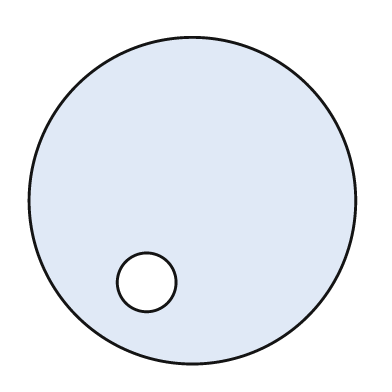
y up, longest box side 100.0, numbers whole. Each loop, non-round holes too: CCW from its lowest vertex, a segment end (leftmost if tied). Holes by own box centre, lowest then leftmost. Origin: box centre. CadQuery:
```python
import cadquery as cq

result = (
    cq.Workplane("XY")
    .moveTo(0.0, 0.0)
    .circle(50.0)
    .moveTo(-14.0, -25.0)
    .circle(9.0)
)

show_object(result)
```